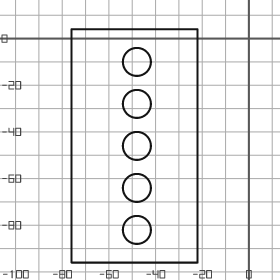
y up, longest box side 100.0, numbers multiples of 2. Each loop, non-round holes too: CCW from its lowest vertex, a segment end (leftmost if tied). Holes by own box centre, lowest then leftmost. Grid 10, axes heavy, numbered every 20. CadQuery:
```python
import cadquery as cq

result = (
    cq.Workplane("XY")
    .moveTo(-76.0, -96.0)
    .lineTo(-22.0, -96.0)
    .lineTo(-22.0, 4.0)
    .lineTo(-76.0, 4.0)
    .close()
    .moveTo(-48.0, -82.0)
    .circle(6.0)
    .moveTo(-48.0, -64.0)
    .circle(6.0)
    .moveTo(-48.0, -46.0)
    .circle(6.0)
    .moveTo(-48.0, -28.0)
    .circle(6.0)
    .moveTo(-48.0, -10.0)
    .circle(6.0)
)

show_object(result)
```